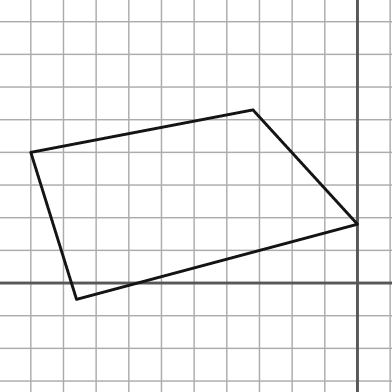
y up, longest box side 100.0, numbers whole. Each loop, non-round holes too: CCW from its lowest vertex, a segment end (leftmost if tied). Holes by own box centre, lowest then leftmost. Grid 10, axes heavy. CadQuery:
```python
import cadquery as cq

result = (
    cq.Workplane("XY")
    .moveTo(-86.0, -5.0)
    .lineTo(0.0, 18.0)
    .lineTo(-32.0, 53.0)
    .lineTo(-100.0, 40.0)
    .close()
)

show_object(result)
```